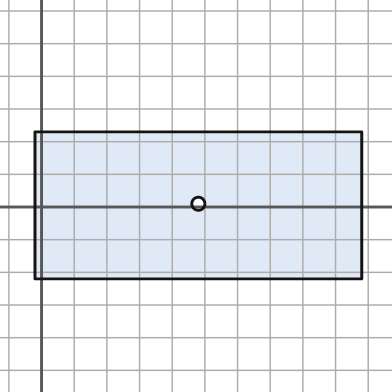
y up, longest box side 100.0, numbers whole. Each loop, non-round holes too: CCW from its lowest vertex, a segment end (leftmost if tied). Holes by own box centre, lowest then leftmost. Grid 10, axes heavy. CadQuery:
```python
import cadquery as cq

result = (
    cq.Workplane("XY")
    .moveTo(-2.0, -22.0)
    .lineTo(98.0, -22.0)
    .lineTo(98.0, 23.0)
    .lineTo(-2.0, 23.0)
    .close()
    .moveTo(48.0, 1.0)
    .circle(2.0)
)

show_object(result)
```